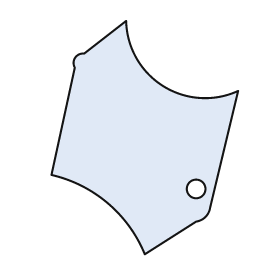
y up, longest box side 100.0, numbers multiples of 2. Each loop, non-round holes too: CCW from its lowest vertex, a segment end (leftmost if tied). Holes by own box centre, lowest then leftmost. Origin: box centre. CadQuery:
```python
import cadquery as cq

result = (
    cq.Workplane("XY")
    .moveTo(0.0, -50.0)
    .lineTo(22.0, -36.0)
    .threePointArc((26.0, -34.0), (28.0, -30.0))
    .lineTo(40.0, 20.0)
    .threePointArc((8.0, 22.0), (-8.0, 50.0))
    .lineTo(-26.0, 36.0)
    .threePointArc((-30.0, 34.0), (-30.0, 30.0))
    .lineTo(-40.0, -16.0)
    .threePointArc((-16.0, -28.0), (0.0, -50.0))
    .close()
    .moveTo(22.0, -22.0)
    .circle(4.0)
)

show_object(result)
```